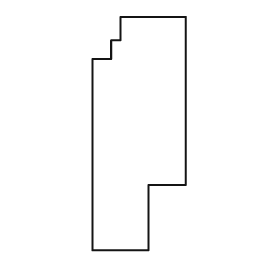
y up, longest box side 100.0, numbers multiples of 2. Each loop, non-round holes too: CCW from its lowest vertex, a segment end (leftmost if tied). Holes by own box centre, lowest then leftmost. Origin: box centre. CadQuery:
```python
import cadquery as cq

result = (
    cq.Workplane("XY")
    .moveTo(-20.0, -50.0)
    .lineTo(4.0, -50.0)
    .lineTo(4.0, -22.0)
    .lineTo(20.0, -22.0)
    .lineTo(20.0, 50.0)
    .lineTo(-8.0, 50.0)
    .lineTo(-8.0, 40.0)
    .lineTo(-12.0, 40.0)
    .lineTo(-12.0, 32.0)
    .lineTo(-20.0, 32.0)
    .close()
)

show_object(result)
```